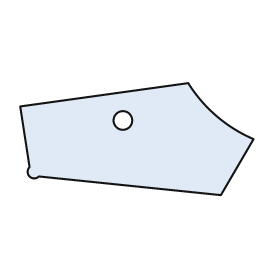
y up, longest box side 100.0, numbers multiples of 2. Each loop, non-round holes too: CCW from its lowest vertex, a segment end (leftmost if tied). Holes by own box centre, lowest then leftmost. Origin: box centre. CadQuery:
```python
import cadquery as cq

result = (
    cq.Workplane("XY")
    .moveTo(36.0, -24.0)
    .lineTo(50.0, 0.0)
    .threePointArc((34.0, 10.0), (22.0, 24.0))
    .lineTo(-50.0, 14.0)
    .lineTo(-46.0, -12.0)
    .threePointArc((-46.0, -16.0), (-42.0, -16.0))
    .close()
    .moveTo(-6.0, 8.0)
    .circle(4.0)
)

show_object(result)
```